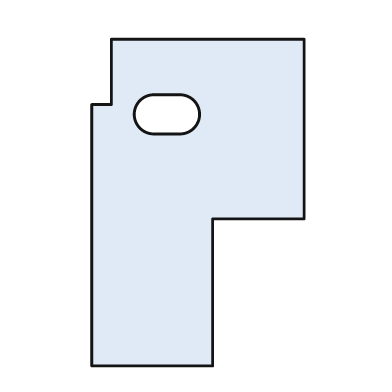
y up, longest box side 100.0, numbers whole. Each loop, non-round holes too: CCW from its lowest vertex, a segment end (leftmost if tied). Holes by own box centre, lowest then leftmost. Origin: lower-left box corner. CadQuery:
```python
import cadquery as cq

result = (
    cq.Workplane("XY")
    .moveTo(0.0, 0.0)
    .lineTo(37.0, 0.0)
    .lineTo(37.0, 45.0)
    .lineTo(65.0, 45.0)
    .lineTo(65.0, 100.0)
    .lineTo(6.0, 100.0)
    .lineTo(6.0, 80.0)
    .lineTo(0.0, 80.0)
    .close()
    .moveTo(19.0, 71.0)
    .lineTo(27.0, 71.0)
    .threePointArc((33.0, 77.0), (27.0, 83.0))
    .lineTo(19.0, 83.0)
    .threePointArc((13.0, 77.0), (19.0, 71.0))
    .close()
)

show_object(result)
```